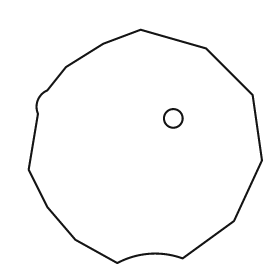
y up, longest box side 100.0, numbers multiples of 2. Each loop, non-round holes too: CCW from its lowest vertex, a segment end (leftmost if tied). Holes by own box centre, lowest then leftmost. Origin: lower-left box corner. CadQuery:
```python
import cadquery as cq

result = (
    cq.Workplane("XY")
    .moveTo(38.0, 0.0)
    .threePointArc((52.0, 4.0), (66.0, 2.0))
    .lineTo(88.0, 18.0)
    .lineTo(100.0, 44.0)
    .lineTo(96.0, 72.0)
    .lineTo(76.0, 92.0)
    .lineTo(48.0, 100.0)
    .lineTo(32.0, 94.0)
    .lineTo(16.0, 84.0)
    .lineTo(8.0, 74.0)
    .threePointArc((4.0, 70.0), (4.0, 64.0))
    .lineTo(0.0, 40.0)
    .lineTo(8.0, 24.0)
    .lineTo(20.0, 10.0)
    .close()
    .moveTo(62.0, 62.0)
    .circle(4.0)
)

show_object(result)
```